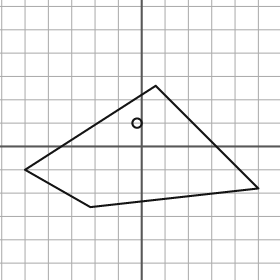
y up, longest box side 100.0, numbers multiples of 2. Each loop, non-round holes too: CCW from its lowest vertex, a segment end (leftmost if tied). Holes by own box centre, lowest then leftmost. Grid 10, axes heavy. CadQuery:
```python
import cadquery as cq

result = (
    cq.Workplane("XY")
    .moveTo(-22.0, -26.0)
    .lineTo(50.0, -18.0)
    .lineTo(6.0, 26.0)
    .lineTo(-50.0, -10.0)
    .close()
    .moveTo(-2.0, 10.0)
    .circle(2.0)
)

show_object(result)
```